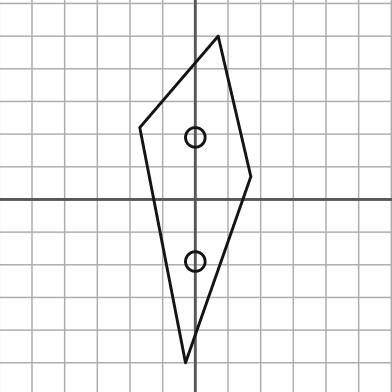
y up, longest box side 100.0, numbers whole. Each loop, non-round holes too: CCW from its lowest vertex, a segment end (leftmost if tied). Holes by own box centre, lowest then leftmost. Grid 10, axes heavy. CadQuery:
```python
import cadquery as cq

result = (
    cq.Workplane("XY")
    .moveTo(-3.0, -50.0)
    .lineTo(17.0, 7.0)
    .lineTo(7.0, 50.0)
    .lineTo(-17.0, 22.0)
    .close()
    .moveTo(0.0, -19.0)
    .circle(3.0)
    .moveTo(0.0, 19.0)
    .circle(3.0)
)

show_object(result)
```